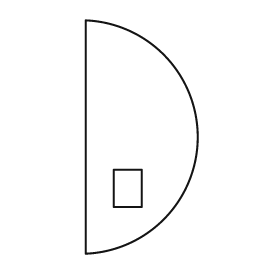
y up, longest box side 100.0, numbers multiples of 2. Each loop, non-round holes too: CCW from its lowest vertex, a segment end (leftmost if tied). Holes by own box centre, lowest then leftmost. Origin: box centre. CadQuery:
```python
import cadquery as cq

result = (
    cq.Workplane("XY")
    .moveTo(-24.0, -50.0)
    .threePointArc((24.0, 0.0), (-24.0, 50.0))
    .close()
    .moveTo(-12.0, -30.0)
    .lineTo(0.0, -30.0)
    .lineTo(0.0, -14.0)
    .lineTo(-12.0, -14.0)
    .close()
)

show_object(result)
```